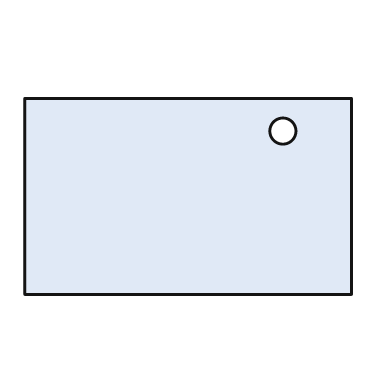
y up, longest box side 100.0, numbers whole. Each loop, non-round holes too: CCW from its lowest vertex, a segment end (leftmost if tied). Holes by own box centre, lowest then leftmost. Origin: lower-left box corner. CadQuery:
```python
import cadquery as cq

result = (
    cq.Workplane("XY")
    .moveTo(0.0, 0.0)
    .lineTo(100.0, 0.0)
    .lineTo(100.0, 60.0)
    .lineTo(0.0, 60.0)
    .close()
    .moveTo(79.0, 50.0)
    .circle(4.0)
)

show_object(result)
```